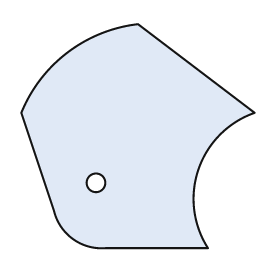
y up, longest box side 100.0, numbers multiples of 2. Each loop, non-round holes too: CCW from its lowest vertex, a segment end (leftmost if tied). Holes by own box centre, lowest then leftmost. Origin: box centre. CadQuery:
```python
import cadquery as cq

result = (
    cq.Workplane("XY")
    .moveTo(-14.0, -48.0)
    .lineTo(30.0, -48.0)
    .threePointArc((26.0, -14.0), (50.0, 10.0))
    .lineTo(0.0, 48.0)
    .threePointArc((-30.0, 36.0), (-50.0, 10.0))
    .lineTo(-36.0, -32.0)
    .threePointArc((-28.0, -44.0), (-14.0, -48.0))
    .close()
    .moveTo(-18.0, -20.0)
    .circle(4.0)
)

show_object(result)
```